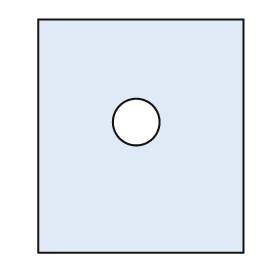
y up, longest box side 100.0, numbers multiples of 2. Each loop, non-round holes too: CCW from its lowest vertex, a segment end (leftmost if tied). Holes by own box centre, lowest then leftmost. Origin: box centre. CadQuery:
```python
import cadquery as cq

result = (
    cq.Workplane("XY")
    .moveTo(-44.0, -50.0)
    .lineTo(44.0, -50.0)
    .lineTo(44.0, 50.0)
    .lineTo(-44.0, 50.0)
    .close()
    .moveTo(-2.0, 6.0)
    .circle(10.0)
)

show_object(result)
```